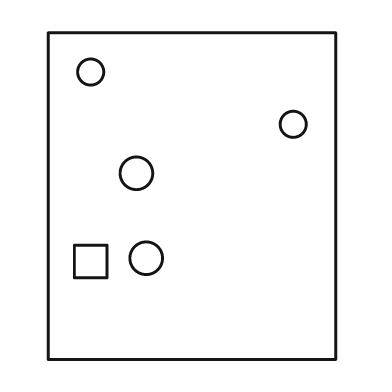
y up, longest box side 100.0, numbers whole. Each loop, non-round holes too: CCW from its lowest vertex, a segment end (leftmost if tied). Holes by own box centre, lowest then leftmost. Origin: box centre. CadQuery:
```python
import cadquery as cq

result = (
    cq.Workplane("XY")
    .moveTo(-44.0, -50.0)
    .lineTo(44.0, -50.0)
    .lineTo(44.0, 50.0)
    .lineTo(-44.0, 50.0)
    .close()
    .moveTo(-36.0, -25.0)
    .lineTo(-26.0, -25.0)
    .lineTo(-26.0, -15.0)
    .lineTo(-36.0, -15.0)
    .close()
    .moveTo(-14.0, -19.0)
    .circle(5.0)
    .moveTo(-17.0, 7.0)
    .circle(5.0)
    .moveTo(31.0, 22.0)
    .circle(4.0)
    .moveTo(-31.0, 38.0)
    .circle(4.0)
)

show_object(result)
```